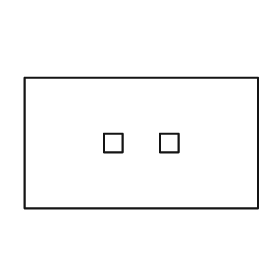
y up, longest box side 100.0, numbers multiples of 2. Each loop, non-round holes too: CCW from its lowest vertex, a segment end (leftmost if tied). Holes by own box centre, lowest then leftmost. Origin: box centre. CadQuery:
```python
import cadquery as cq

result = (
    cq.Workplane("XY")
    .moveTo(-50.0, -28.0)
    .lineTo(50.0, -28.0)
    .lineTo(50.0, 28.0)
    .lineTo(-50.0, 28.0)
    .close()
    .moveTo(-16.0, -4.0)
    .lineTo(-8.0, -4.0)
    .lineTo(-8.0, 4.0)
    .lineTo(-16.0, 4.0)
    .close()
    .moveTo(8.0, -4.0)
    .lineTo(16.0, -4.0)
    .lineTo(16.0, 4.0)
    .lineTo(8.0, 4.0)
    .close()
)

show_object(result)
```